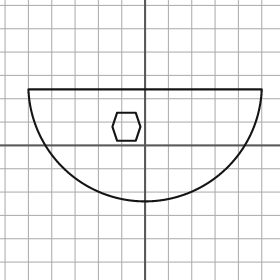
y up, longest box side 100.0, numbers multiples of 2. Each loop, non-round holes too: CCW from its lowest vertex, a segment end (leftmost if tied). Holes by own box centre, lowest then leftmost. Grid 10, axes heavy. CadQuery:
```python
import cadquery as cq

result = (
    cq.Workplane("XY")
    .moveTo(-50.0, 24.0)
    .threePointArc((0.0, -24.0), (50.0, 24.0))
    .close()
    .moveTo(-12.0, 2.0)
    .lineTo(-4.0, 2.0)
    .lineTo(-2.0, 8.0)
    .lineTo(-4.0, 14.0)
    .lineTo(-12.0, 14.0)
    .lineTo(-14.0, 8.0)
    .close()
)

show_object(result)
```